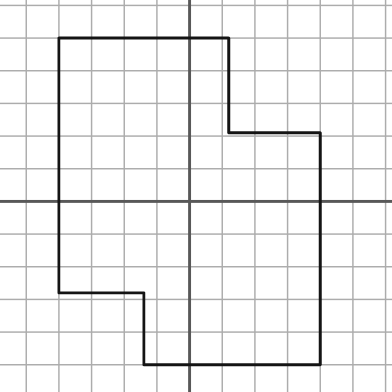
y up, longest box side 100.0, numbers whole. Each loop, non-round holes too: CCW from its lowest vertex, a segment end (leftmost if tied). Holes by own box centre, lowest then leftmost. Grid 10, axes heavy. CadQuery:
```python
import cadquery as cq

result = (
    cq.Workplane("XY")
    .moveTo(-14.0, -50.0)
    .lineTo(40.0, -50.0)
    .lineTo(40.0, 21.0)
    .lineTo(12.0, 21.0)
    .lineTo(12.0, 50.0)
    .lineTo(-40.0, 50.0)
    .lineTo(-40.0, -28.0)
    .lineTo(-14.0, -28.0)
    .close()
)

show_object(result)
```